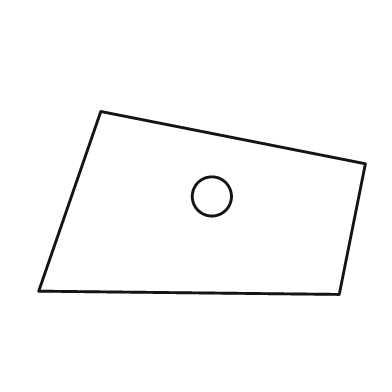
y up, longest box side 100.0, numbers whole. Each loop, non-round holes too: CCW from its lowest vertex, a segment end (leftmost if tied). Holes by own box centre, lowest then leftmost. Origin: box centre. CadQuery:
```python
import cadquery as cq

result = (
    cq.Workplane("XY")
    .moveTo(42.0, -28.0)
    .lineTo(50.0, 12.0)
    .lineTo(-31.0, 28.0)
    .lineTo(-50.0, -27.0)
    .close()
    .moveTo(3.0, 2.0)
    .circle(6.0)
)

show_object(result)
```